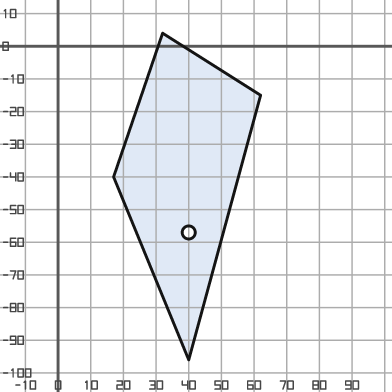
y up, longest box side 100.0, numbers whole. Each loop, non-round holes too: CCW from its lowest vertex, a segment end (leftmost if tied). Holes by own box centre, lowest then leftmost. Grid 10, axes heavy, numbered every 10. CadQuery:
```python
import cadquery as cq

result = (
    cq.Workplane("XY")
    .moveTo(40.0, -96.0)
    .lineTo(62.0, -15.0)
    .lineTo(32.0, 4.0)
    .lineTo(17.0, -40.0)
    .close()
    .moveTo(40.0, -57.0)
    .circle(2.0)
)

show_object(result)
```